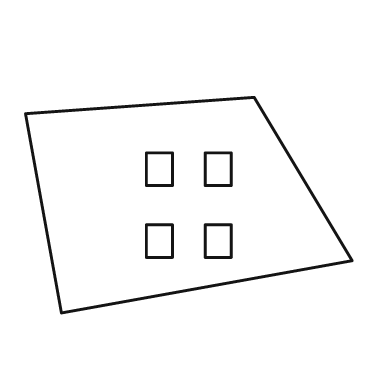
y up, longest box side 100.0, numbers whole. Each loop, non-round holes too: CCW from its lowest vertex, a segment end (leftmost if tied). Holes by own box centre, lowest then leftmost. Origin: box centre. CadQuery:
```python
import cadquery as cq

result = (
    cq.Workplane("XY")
    .moveTo(-39.0, -33.0)
    .lineTo(50.0, -17.0)
    .lineTo(20.0, 33.0)
    .lineTo(-50.0, 28.0)
    .close()
    .moveTo(-13.0, -16.0)
    .lineTo(-5.0, -16.0)
    .lineTo(-5.0, -6.0)
    .lineTo(-13.0, -6.0)
    .close()
    .moveTo(5.0, -16.0)
    .lineTo(13.0, -16.0)
    .lineTo(13.0, -6.0)
    .lineTo(5.0, -6.0)
    .close()
    .moveTo(-13.0, 6.0)
    .lineTo(-5.0, 6.0)
    .lineTo(-5.0, 16.0)
    .lineTo(-13.0, 16.0)
    .close()
    .moveTo(5.0, 6.0)
    .lineTo(13.0, 6.0)
    .lineTo(13.0, 16.0)
    .lineTo(5.0, 16.0)
    .close()
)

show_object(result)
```